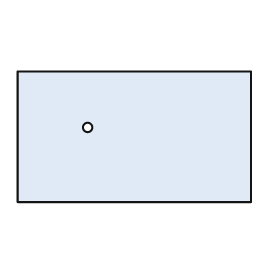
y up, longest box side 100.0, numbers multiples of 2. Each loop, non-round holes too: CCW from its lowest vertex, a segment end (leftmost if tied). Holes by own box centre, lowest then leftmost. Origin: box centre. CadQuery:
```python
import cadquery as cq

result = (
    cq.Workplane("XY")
    .moveTo(-50.0, -28.0)
    .lineTo(50.0, -28.0)
    .lineTo(50.0, 28.0)
    .lineTo(-50.0, 28.0)
    .close()
    .moveTo(-20.0, 4.0)
    .circle(2.0)
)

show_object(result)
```